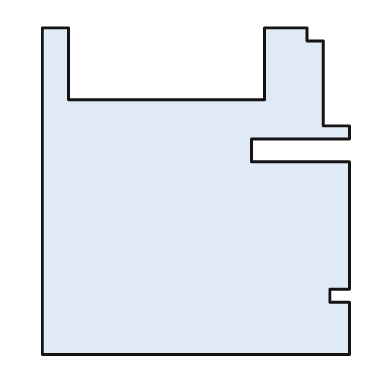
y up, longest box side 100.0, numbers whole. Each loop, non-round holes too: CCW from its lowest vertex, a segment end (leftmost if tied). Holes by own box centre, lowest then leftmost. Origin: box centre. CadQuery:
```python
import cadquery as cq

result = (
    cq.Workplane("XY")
    .moveTo(-47.0, -50.0)
    .lineTo(47.0, -50.0)
    .lineTo(47.0, -34.0)
    .lineTo(41.0, -34.0)
    .lineTo(41.0, -30.0)
    .lineTo(47.0, -30.0)
    .lineTo(47.0, 9.0)
    .lineTo(17.0, 9.0)
    .lineTo(17.0, 16.0)
    .lineTo(47.0, 16.0)
    .lineTo(47.0, 20.0)
    .lineTo(39.0, 20.0)
    .lineTo(39.0, 46.0)
    .lineTo(34.0, 46.0)
    .lineTo(34.0, 50.0)
    .lineTo(21.0, 50.0)
    .lineTo(21.0, 28.0)
    .lineTo(-39.0, 28.0)
    .lineTo(-39.0, 50.0)
    .lineTo(-47.0, 50.0)
    .close()
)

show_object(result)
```